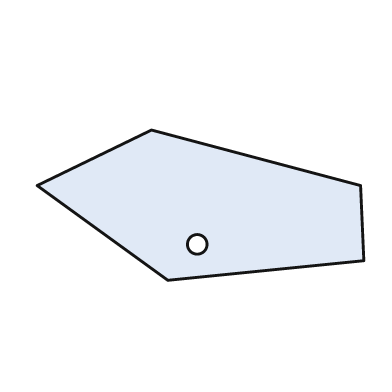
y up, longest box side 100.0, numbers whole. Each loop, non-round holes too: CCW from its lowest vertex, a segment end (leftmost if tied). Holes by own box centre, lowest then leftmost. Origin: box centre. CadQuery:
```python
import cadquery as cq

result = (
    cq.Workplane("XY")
    .moveTo(-10.0, -23.0)
    .lineTo(50.0, -17.0)
    .lineTo(49.0, 6.0)
    .lineTo(-15.0, 23.0)
    .lineTo(-50.0, 6.0)
    .close()
    .moveTo(-1.0, -12.0)
    .circle(3.0)
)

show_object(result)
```